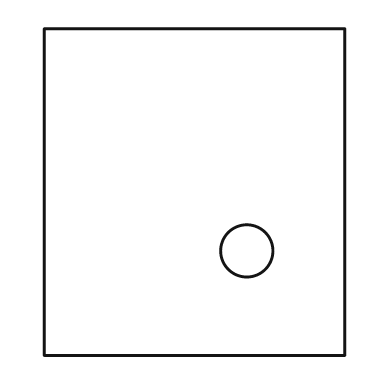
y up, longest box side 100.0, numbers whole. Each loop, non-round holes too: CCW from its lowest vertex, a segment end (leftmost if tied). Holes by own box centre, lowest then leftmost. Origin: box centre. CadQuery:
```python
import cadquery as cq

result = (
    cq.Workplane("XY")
    .moveTo(-46.0, -50.0)
    .lineTo(46.0, -50.0)
    .lineTo(46.0, 50.0)
    .lineTo(-46.0, 50.0)
    .close()
    .moveTo(16.0, -18.0)
    .circle(8.0)
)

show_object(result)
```